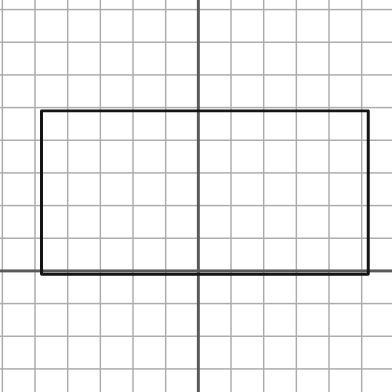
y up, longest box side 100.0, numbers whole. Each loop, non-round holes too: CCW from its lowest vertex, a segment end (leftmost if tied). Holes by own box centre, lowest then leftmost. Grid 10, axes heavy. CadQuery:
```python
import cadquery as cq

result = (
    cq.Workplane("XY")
    .moveTo(-48.0, -1.0)
    .lineTo(52.0, -1.0)
    .lineTo(52.0, 49.0)
    .lineTo(-48.0, 49.0)
    .close()
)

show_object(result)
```